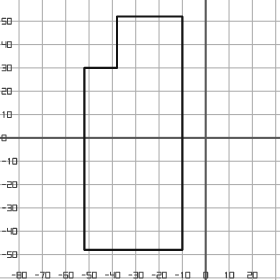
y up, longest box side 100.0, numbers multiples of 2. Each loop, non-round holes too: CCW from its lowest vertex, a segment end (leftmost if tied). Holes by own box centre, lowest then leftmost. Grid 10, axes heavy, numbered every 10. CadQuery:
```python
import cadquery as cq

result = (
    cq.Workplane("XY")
    .moveTo(-52.0, -48.0)
    .lineTo(-10.0, -48.0)
    .lineTo(-10.0, 52.0)
    .lineTo(-38.0, 52.0)
    .lineTo(-38.0, 30.0)
    .lineTo(-52.0, 30.0)
    .close()
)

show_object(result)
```